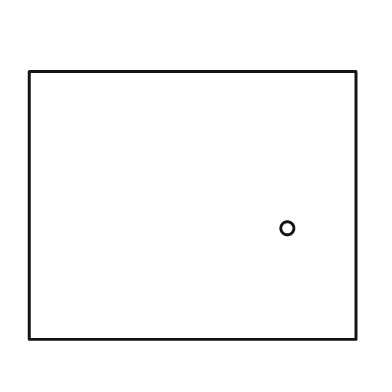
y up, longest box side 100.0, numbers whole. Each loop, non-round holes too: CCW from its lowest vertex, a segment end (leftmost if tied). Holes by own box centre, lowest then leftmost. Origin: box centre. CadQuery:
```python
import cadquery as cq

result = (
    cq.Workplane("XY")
    .moveTo(-50.0, -41.0)
    .lineTo(50.0, -41.0)
    .lineTo(50.0, 41.0)
    .lineTo(-50.0, 41.0)
    .close()
    .moveTo(29.0, -7.0)
    .circle(2.0)
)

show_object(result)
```